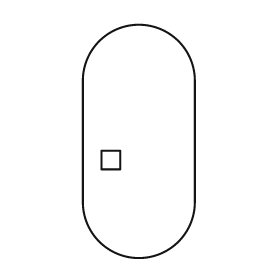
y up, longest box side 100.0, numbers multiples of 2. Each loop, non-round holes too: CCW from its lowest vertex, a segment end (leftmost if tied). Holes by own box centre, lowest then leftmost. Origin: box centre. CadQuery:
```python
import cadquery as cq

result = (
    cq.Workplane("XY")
    .moveTo(-24.0, -26.0)
    .threePointArc((0.0, -50.0), (24.0, -26.0))
    .lineTo(24.0, 26.0)
    .threePointArc((0.0, 50.0), (-24.0, 26.0))
    .close()
    .moveTo(-16.0, -12.0)
    .lineTo(-8.0, -12.0)
    .lineTo(-8.0, -4.0)
    .lineTo(-16.0, -4.0)
    .close()
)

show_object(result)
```